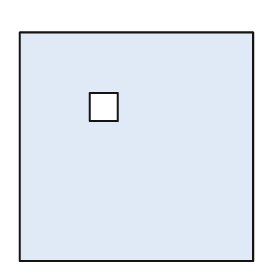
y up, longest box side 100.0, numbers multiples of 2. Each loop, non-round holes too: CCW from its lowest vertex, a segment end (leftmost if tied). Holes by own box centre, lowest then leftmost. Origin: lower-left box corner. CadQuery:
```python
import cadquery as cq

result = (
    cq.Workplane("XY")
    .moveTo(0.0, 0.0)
    .lineTo(100.0, 0.0)
    .lineTo(100.0, 98.0)
    .lineTo(0.0, 98.0)
    .close()
    .moveTo(30.0, 60.0)
    .lineTo(42.0, 60.0)
    .lineTo(42.0, 72.0)
    .lineTo(30.0, 72.0)
    .close()
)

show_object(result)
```